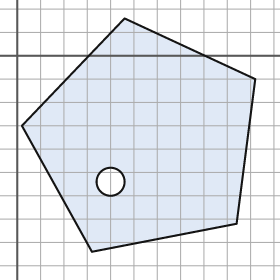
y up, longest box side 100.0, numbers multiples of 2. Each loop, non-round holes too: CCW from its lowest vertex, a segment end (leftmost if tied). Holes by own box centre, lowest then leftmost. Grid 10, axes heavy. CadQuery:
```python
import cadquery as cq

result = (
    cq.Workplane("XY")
    .moveTo(32.0, -84.0)
    .lineTo(94.0, -72.0)
    .lineTo(102.0, -10.0)
    .lineTo(46.0, 16.0)
    .lineTo(2.0, -30.0)
    .close()
    .moveTo(40.0, -54.0)
    .circle(6.0)
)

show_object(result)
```